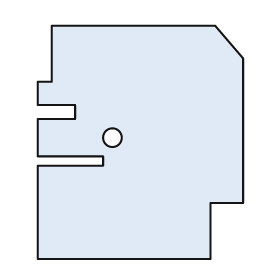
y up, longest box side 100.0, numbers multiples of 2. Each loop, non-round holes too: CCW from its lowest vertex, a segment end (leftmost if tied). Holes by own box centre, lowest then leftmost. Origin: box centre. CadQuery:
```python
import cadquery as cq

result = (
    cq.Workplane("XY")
    .moveTo(-44.0, -50.0)
    .lineTo(30.0, -50.0)
    .lineTo(30.0, -26.0)
    .lineTo(44.0, -26.0)
    .lineTo(44.0, 36.0)
    .lineTo(32.0, 50.0)
    .lineTo(-38.0, 50.0)
    .lineTo(-38.0, 26.0)
    .lineTo(-44.0, 26.0)
    .lineTo(-44.0, 16.0)
    .lineTo(-28.0, 16.0)
    .lineTo(-28.0, 10.0)
    .lineTo(-44.0, 10.0)
    .lineTo(-44.0, -6.0)
    .lineTo(-16.0, -6.0)
    .lineTo(-16.0, -10.0)
    .lineTo(-44.0, -10.0)
    .close()
    .moveTo(-12.0, 2.0)
    .circle(4.0)
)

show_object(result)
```